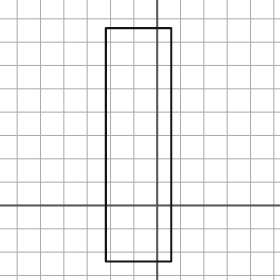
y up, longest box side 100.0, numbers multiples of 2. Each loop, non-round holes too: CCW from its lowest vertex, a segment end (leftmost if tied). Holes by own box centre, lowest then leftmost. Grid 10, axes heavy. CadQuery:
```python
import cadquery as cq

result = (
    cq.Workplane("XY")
    .moveTo(-22.0, -24.0)
    .lineTo(6.0, -24.0)
    .lineTo(6.0, 76.0)
    .lineTo(-22.0, 76.0)
    .close()
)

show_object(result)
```